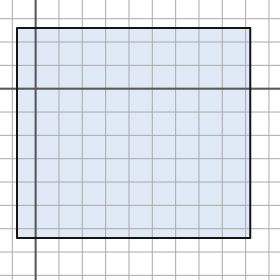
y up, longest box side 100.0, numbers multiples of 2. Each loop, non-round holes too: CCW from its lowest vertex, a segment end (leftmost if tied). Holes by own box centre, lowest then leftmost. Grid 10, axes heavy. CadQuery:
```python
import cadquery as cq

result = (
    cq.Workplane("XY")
    .moveTo(-8.0, -64.0)
    .lineTo(92.0, -64.0)
    .lineTo(92.0, 26.0)
    .lineTo(-8.0, 26.0)
    .close()
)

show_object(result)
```